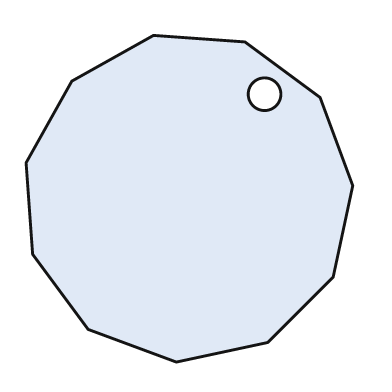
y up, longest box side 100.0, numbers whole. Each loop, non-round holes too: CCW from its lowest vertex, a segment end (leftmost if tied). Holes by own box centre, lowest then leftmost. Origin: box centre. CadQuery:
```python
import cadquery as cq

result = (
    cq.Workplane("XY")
    .moveTo(-4.0, -50.0)
    .lineTo(24.0, -44.0)
    .lineTo(44.0, -24.0)
    .lineTo(50.0, 4.0)
    .lineTo(40.0, 31.0)
    .lineTo(17.0, 48.0)
    .lineTo(-11.0, 50.0)
    .lineTo(-36.0, 36.0)
    .lineTo(-50.0, 11.0)
    .lineTo(-48.0, -17.0)
    .lineTo(-31.0, -40.0)
    .close()
    .moveTo(23.0, 32.0)
    .circle(5.0)
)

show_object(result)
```